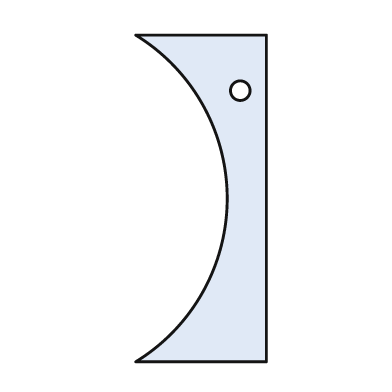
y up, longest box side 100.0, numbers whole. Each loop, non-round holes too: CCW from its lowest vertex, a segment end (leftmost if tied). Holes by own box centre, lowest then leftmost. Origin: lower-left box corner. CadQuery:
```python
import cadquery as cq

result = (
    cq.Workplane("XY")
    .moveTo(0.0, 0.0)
    .lineTo(40.0, 0.0)
    .lineTo(40.0, 100.0)
    .lineTo(0.0, 100.0)
    .threePointArc((28.0, 50.0), (0.0, 0.0))
    .close()
    .moveTo(32.0, 83.0)
    .circle(3.0)
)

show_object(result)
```